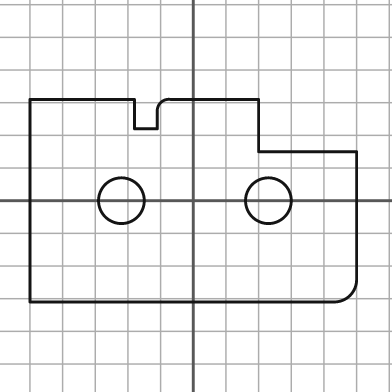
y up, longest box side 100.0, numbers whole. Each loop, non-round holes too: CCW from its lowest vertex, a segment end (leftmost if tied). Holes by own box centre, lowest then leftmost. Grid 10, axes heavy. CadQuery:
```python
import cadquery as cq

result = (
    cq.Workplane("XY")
    .moveTo(-50.0, -31.0)
    .lineTo(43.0, -31.0)
    .threePointArc((48.0, -29.0), (50.0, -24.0))
    .lineTo(50.0, 15.0)
    .lineTo(20.0, 15.0)
    .lineTo(20.0, 31.0)
    .lineTo(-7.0, 31.0)
    .threePointArc((-10.0, 30.0), (-11.0, 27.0))
    .lineTo(-11.0, 22.0)
    .lineTo(-18.0, 22.0)
    .lineTo(-18.0, 31.0)
    .lineTo(-50.0, 31.0)
    .close()
    .moveTo(-22.0, 0.0)
    .circle(7.0)
    .moveTo(23.0, 0.0)
    .circle(7.0)
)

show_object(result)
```